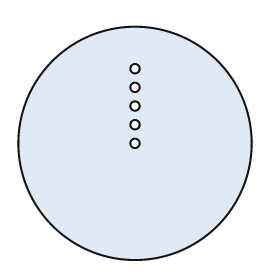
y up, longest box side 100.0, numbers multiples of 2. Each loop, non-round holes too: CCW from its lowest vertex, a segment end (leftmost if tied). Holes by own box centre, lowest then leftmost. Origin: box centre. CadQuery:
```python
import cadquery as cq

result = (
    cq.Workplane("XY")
    .moveTo(0.0, 0.0)
    .circle(50.0)
    .moveTo(0.0, 0.0)
    .circle(2.0)
    .moveTo(0.0, 8.0)
    .circle(2.0)
    .moveTo(0.0, 16.0)
    .circle(2.0)
    .moveTo(0.0, 24.0)
    .circle(2.0)
    .moveTo(0.0, 32.0)
    .circle(2.0)
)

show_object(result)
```